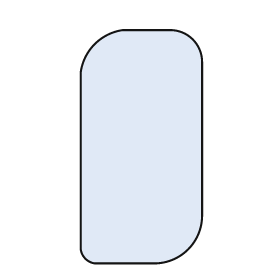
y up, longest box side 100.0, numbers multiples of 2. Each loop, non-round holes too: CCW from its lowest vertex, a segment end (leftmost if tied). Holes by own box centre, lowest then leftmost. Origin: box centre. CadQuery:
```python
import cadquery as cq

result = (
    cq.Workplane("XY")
    .moveTo(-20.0, -50.0)
    .lineTo(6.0, -50.0)
    .threePointArc((20.0, -44.0), (26.0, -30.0))
    .lineTo(26.0, 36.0)
    .threePointArc((22.0, 46.0), (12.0, 50.0))
    .lineTo(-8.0, 50.0)
    .threePointArc((-20.0, 44.0), (-26.0, 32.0))
    .lineTo(-26.0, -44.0)
    .threePointArc((-24.0, -48.0), (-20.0, -50.0))
    .close()
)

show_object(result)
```